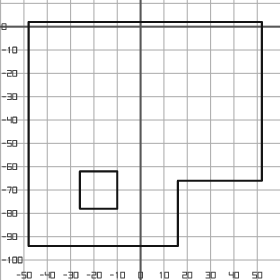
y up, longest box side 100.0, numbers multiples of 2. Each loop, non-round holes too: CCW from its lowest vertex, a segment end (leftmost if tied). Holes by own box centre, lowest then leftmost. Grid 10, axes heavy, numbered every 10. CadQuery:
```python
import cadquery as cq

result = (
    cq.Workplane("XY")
    .moveTo(-48.0, -94.0)
    .lineTo(16.0, -94.0)
    .lineTo(16.0, -66.0)
    .lineTo(52.0, -66.0)
    .lineTo(52.0, 2.0)
    .lineTo(-48.0, 2.0)
    .close()
    .moveTo(-26.0, -78.0)
    .lineTo(-10.0, -78.0)
    .lineTo(-10.0, -62.0)
    .lineTo(-26.0, -62.0)
    .close()
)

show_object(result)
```